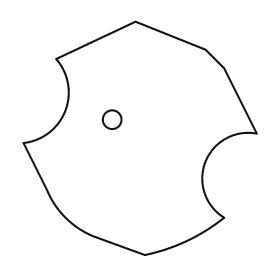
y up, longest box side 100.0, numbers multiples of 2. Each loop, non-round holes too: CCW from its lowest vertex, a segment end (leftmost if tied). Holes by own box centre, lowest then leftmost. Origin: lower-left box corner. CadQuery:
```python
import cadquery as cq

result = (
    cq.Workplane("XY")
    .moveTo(52.0, 0.0)
    .threePointArc((70.0, 6.0), (86.0, 16.0))
    .threePointArc((78.0, 40.0), (100.0, 52.0))
    .lineTo(86.0, 80.0)
    .lineTo(78.0, 88.0)
    .lineTo(48.0, 100.0)
    .lineTo(14.0, 84.0)
    .threePointArc((18.0, 62.0), (0.0, 48.0))
    .lineTo(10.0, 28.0)
    .threePointArc((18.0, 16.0), (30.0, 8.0))
    .close()
    .moveTo(38.0, 58.0)
    .circle(4.0)
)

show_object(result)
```